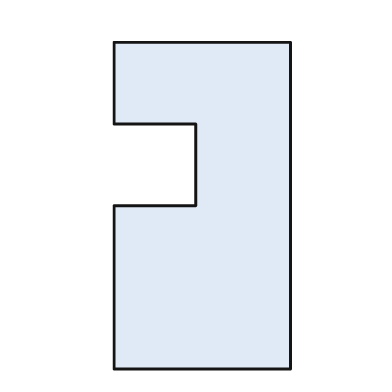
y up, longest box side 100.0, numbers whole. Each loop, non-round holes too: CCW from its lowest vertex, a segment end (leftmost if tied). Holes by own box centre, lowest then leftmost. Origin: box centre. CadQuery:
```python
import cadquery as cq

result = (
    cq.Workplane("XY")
    .moveTo(-27.0, -50.0)
    .lineTo(27.0, -50.0)
    .lineTo(27.0, 50.0)
    .lineTo(-27.0, 50.0)
    .lineTo(-27.0, 25.0)
    .lineTo(-2.0, 25.0)
    .lineTo(-2.0, 0.0)
    .lineTo(-27.0, 0.0)
    .close()
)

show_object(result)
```